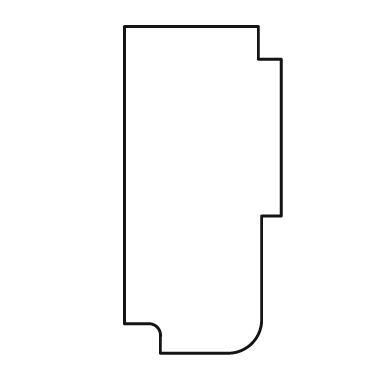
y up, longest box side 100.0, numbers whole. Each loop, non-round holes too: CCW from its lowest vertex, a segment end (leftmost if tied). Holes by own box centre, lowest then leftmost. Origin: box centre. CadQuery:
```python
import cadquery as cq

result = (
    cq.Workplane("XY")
    .moveTo(-13.0, -50.0)
    .lineTo(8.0, -50.0)
    .threePointArc((15.0, -47.0), (18.0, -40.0))
    .lineTo(18.0, -8.0)
    .lineTo(24.0, -8.0)
    .lineTo(24.0, 40.0)
    .lineTo(17.0, 40.0)
    .lineTo(17.0, 50.0)
    .lineTo(-24.0, 50.0)
    .lineTo(-24.0, -41.0)
    .lineTo(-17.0, -41.0)
    .threePointArc((-14.0, -42.0), (-13.0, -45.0))
    .close()
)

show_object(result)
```